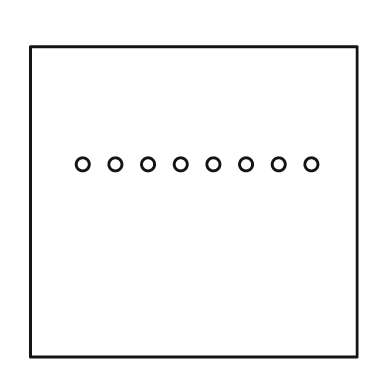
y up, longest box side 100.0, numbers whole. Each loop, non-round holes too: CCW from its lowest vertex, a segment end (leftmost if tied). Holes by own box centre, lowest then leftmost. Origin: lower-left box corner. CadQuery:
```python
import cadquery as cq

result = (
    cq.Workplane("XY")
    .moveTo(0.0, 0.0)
    .lineTo(100.0, 0.0)
    .lineTo(100.0, 95.0)
    .lineTo(0.0, 95.0)
    .close()
    .moveTo(16.0, 59.0)
    .circle(2.0)
    .moveTo(26.0, 59.0)
    .circle(2.0)
    .moveTo(36.0, 59.0)
    .circle(2.0)
    .moveTo(46.0, 59.0)
    .circle(2.0)
    .moveTo(56.0, 59.0)
    .circle(2.0)
    .moveTo(66.0, 59.0)
    .circle(2.0)
    .moveTo(76.0, 59.0)
    .circle(2.0)
    .moveTo(86.0, 59.0)
    .circle(2.0)
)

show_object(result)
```